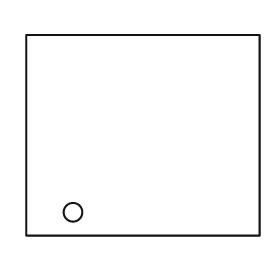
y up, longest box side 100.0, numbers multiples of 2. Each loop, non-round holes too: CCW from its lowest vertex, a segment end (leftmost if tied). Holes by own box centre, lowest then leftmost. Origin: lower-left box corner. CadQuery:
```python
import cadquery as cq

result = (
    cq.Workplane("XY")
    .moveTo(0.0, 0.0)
    .lineTo(100.0, 0.0)
    .lineTo(100.0, 86.0)
    .lineTo(0.0, 86.0)
    .close()
    .moveTo(20.0, 10.0)
    .circle(4.0)
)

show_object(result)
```